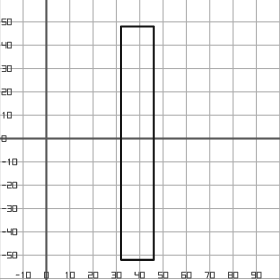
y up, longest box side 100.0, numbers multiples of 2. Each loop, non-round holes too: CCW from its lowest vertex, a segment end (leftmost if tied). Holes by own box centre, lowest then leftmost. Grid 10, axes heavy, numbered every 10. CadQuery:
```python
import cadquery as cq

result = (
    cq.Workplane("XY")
    .moveTo(32.0, -52.0)
    .lineTo(46.0, -52.0)
    .lineTo(46.0, 48.0)
    .lineTo(32.0, 48.0)
    .close()
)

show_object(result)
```